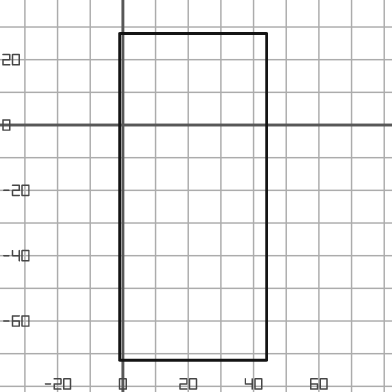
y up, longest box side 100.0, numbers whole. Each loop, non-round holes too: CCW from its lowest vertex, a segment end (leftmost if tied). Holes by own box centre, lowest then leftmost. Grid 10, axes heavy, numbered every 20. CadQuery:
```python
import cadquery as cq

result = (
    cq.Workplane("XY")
    .moveTo(-1.0, -72.0)
    .lineTo(44.0, -72.0)
    .lineTo(44.0, 28.0)
    .lineTo(-1.0, 28.0)
    .close()
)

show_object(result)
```